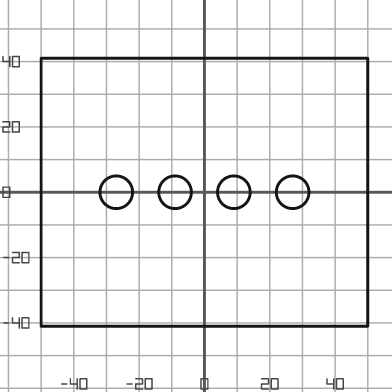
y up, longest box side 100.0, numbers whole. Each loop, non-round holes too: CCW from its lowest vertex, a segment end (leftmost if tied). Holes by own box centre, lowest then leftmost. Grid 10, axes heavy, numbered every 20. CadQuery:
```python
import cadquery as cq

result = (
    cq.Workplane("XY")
    .moveTo(-50.0, -41.0)
    .lineTo(50.0, -41.0)
    .lineTo(50.0, 41.0)
    .lineTo(-50.0, 41.0)
    .close()
    .moveTo(-27.0, 0.0)
    .circle(5.0)
    .moveTo(-9.0, 0.0)
    .circle(5.0)
    .moveTo(9.0, 0.0)
    .circle(5.0)
    .moveTo(27.0, 0.0)
    .circle(5.0)
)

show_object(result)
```